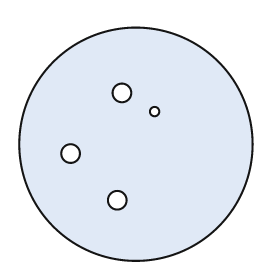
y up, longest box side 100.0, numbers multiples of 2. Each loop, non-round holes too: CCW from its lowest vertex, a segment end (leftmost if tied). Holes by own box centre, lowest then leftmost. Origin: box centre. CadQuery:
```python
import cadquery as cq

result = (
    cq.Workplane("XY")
    .moveTo(0.0, 0.0)
    .circle(50.0)
    .moveTo(-8.0, -24.0)
    .circle(4.0)
    .moveTo(-28.0, -4.0)
    .circle(4.0)
    .moveTo(8.0, 14.0)
    .circle(2.0)
    .moveTo(-6.0, 22.0)
    .circle(4.0)
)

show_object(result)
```